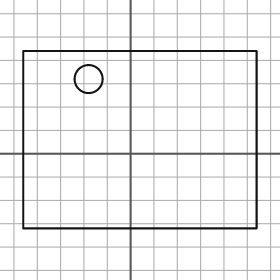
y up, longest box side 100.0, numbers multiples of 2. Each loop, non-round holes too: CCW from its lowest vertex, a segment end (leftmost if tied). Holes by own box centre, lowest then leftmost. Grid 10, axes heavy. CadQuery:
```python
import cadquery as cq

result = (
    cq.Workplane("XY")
    .moveTo(-46.0, -32.0)
    .lineTo(54.0, -32.0)
    .lineTo(54.0, 44.0)
    .lineTo(-46.0, 44.0)
    .close()
    .moveTo(-18.0, 32.0)
    .circle(6.0)
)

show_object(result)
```